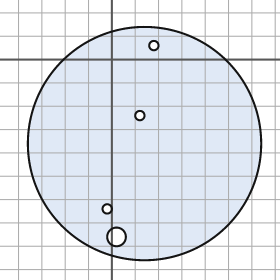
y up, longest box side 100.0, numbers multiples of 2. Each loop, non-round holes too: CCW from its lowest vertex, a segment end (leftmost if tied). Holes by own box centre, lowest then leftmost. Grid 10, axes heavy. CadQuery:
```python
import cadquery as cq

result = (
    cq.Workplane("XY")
    .moveTo(14.0, -36.0)
    .circle(50.0)
    .moveTo(2.0, -76.0)
    .circle(4.0)
    .moveTo(-2.0, -64.0)
    .circle(2.0)
    .moveTo(12.0, -24.0)
    .circle(2.0)
    .moveTo(18.0, 6.0)
    .circle(2.0)
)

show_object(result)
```